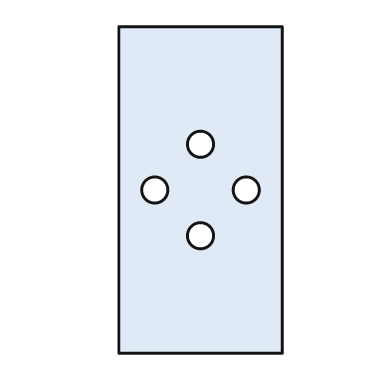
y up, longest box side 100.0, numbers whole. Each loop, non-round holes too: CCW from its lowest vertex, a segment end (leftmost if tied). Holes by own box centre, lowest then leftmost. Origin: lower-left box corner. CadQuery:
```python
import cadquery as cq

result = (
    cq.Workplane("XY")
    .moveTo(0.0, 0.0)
    .lineTo(50.0, 0.0)
    .lineTo(50.0, 100.0)
    .lineTo(0.0, 100.0)
    .close()
    .moveTo(25.0, 36.0)
    .circle(4.0)
    .moveTo(11.0, 50.0)
    .circle(4.0)
    .moveTo(39.0, 50.0)
    .circle(4.0)
    .moveTo(25.0, 64.0)
    .circle(4.0)
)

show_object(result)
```